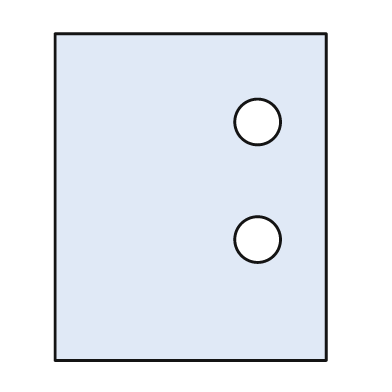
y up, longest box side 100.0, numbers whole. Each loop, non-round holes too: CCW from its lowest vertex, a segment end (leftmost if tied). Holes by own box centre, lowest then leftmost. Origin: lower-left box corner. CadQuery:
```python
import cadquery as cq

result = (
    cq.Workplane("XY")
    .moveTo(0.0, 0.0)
    .lineTo(83.0, 0.0)
    .lineTo(83.0, 100.0)
    .lineTo(0.0, 100.0)
    .close()
    .moveTo(62.0, 37.0)
    .circle(7.0)
    .moveTo(62.0, 73.0)
    .circle(7.0)
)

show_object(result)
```